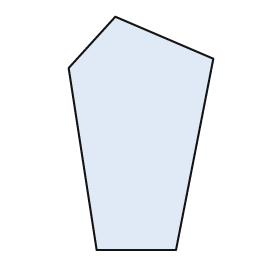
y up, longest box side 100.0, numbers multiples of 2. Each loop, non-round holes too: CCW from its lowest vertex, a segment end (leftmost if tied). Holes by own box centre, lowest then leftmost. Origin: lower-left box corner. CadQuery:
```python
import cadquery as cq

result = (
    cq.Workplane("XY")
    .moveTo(12.0, 0.0)
    .lineTo(46.0, 0.0)
    .lineTo(62.0, 82.0)
    .lineTo(20.0, 100.0)
    .lineTo(0.0, 78.0)
    .close()
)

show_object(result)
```